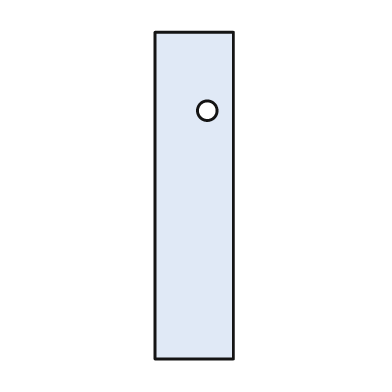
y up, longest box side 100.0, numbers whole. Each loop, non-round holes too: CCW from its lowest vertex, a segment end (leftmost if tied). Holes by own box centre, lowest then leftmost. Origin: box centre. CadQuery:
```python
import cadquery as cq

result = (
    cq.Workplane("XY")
    .moveTo(-12.0, -50.0)
    .lineTo(12.0, -50.0)
    .lineTo(12.0, 50.0)
    .lineTo(-12.0, 50.0)
    .close()
    .moveTo(4.0, 26.0)
    .circle(3.0)
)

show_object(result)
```